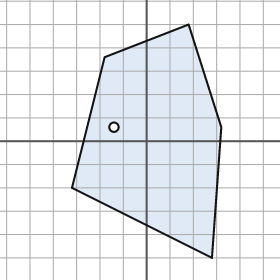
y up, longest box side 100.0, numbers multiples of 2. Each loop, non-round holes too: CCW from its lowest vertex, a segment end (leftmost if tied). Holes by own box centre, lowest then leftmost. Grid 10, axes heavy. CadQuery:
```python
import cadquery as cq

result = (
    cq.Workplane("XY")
    .moveTo(28.0, -50.0)
    .lineTo(32.0, 6.0)
    .lineTo(18.0, 50.0)
    .lineTo(-18.0, 36.0)
    .lineTo(-32.0, -20.0)
    .close()
    .moveTo(-14.0, 6.0)
    .circle(2.0)
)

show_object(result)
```